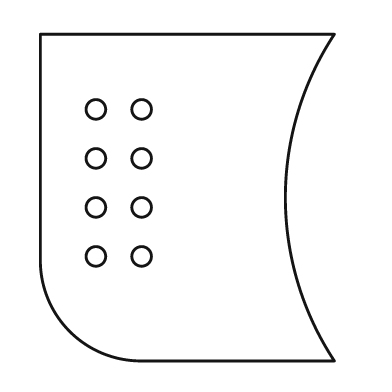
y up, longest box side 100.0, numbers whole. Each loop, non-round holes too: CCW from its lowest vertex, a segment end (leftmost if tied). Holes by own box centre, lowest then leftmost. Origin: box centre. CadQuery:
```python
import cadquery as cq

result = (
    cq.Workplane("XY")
    .moveTo(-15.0, -50.0)
    .lineTo(45.0, -50.0)
    .threePointArc((30.0, 0.0), (45.0, 50.0))
    .lineTo(-45.0, 50.0)
    .lineTo(-45.0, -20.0)
    .threePointArc((-36.0, -41.0), (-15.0, -50.0))
    .close()
    .moveTo(-28.0, -18.0)
    .circle(3.0)
    .moveTo(-14.0, -18.0)
    .circle(3.0)
    .moveTo(-28.0, -3.0)
    .circle(3.0)
    .moveTo(-14.0, -3.0)
    .circle(3.0)
    .moveTo(-28.0, 12.0)
    .circle(3.0)
    .moveTo(-14.0, 12.0)
    .circle(3.0)
    .moveTo(-28.0, 27.0)
    .circle(3.0)
    .moveTo(-14.0, 27.0)
    .circle(3.0)
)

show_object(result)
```